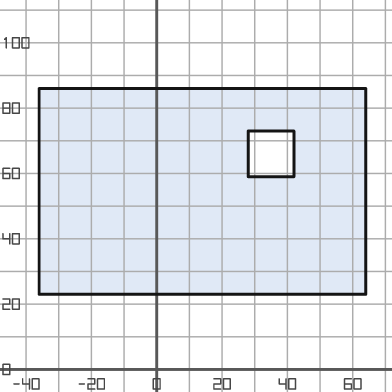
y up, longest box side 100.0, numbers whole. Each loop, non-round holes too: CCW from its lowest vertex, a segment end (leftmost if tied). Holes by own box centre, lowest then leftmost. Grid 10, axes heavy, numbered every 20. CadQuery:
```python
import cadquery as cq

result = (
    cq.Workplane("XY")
    .moveTo(-36.0, 23.0)
    .lineTo(64.0, 23.0)
    .lineTo(64.0, 86.0)
    .lineTo(-36.0, 86.0)
    .close()
    .moveTo(28.0, 59.0)
    .lineTo(42.0, 59.0)
    .lineTo(42.0, 73.0)
    .lineTo(28.0, 73.0)
    .close()
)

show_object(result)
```